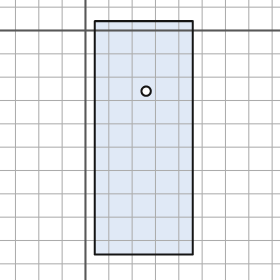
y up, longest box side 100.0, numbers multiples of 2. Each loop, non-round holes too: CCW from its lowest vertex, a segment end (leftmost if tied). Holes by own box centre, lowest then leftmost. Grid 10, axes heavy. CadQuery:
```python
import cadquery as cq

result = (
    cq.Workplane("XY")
    .moveTo(4.0, -96.0)
    .lineTo(46.0, -96.0)
    .lineTo(46.0, 4.0)
    .lineTo(4.0, 4.0)
    .close()
    .moveTo(26.0, -26.0)
    .circle(2.0)
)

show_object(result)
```